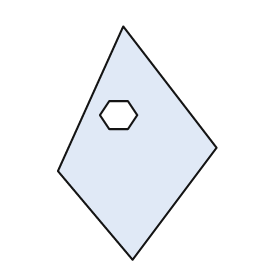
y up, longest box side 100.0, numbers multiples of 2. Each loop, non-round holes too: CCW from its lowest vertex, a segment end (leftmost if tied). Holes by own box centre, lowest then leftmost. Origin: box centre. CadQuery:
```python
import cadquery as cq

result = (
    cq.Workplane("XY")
    .moveTo(-2.0, -50.0)
    .lineTo(34.0, -2.0)
    .lineTo(-6.0, 50.0)
    .lineTo(-34.0, -12.0)
    .close()
    .moveTo(-12.0, 6.0)
    .lineTo(-4.0, 6.0)
    .lineTo(0.0, 12.0)
    .lineTo(-4.0, 18.0)
    .lineTo(-12.0, 18.0)
    .lineTo(-16.0, 12.0)
    .close()
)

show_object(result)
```